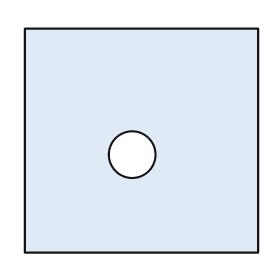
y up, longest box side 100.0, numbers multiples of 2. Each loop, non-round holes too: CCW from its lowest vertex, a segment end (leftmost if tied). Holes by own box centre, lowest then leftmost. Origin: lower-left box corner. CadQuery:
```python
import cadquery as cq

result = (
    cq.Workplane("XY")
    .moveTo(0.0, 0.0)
    .lineTo(100.0, 0.0)
    .lineTo(100.0, 96.0)
    .lineTo(0.0, 96.0)
    .close()
    .moveTo(46.0, 42.0)
    .circle(10.0)
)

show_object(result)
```